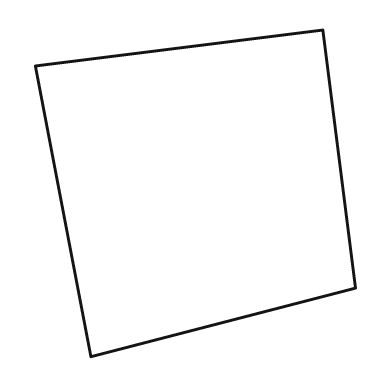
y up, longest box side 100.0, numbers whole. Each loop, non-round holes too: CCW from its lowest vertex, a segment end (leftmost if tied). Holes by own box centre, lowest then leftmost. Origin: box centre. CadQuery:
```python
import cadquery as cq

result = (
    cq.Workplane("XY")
    .moveTo(-32.0, -50.0)
    .lineTo(49.0, -29.0)
    .lineTo(39.0, 50.0)
    .lineTo(-49.0, 39.0)
    .close()
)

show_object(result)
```